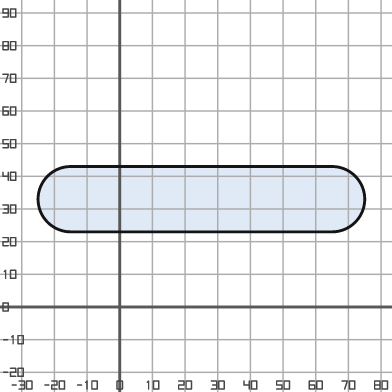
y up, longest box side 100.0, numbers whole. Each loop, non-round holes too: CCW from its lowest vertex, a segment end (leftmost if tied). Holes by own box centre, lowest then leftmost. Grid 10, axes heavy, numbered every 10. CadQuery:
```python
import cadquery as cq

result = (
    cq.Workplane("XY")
    .moveTo(-15.0, 23.0)
    .lineTo(65.0, 23.0)
    .threePointArc((75.0, 33.0), (65.0, 43.0))
    .lineTo(-15.0, 43.0)
    .threePointArc((-25.0, 33.0), (-15.0, 23.0))
    .close()
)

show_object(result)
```